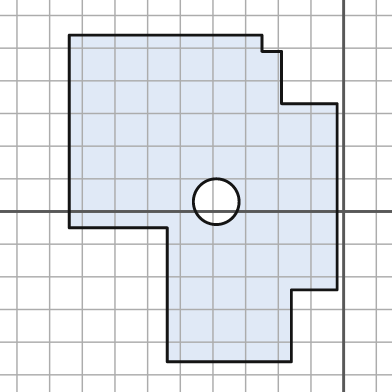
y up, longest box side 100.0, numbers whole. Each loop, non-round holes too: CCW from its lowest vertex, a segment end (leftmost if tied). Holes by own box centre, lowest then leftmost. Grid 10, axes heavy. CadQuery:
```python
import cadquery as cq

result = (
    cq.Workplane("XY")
    .moveTo(-54.0, -46.0)
    .lineTo(-16.0, -46.0)
    .lineTo(-16.0, -24.0)
    .lineTo(-2.0, -24.0)
    .lineTo(-2.0, 33.0)
    .lineTo(-19.0, 33.0)
    .lineTo(-19.0, 49.0)
    .lineTo(-25.0, 49.0)
    .lineTo(-25.0, 54.0)
    .lineTo(-84.0, 54.0)
    .lineTo(-84.0, -5.0)
    .lineTo(-54.0, -5.0)
    .close()
    .moveTo(-39.0, 3.0)
    .circle(7.0)
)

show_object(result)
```